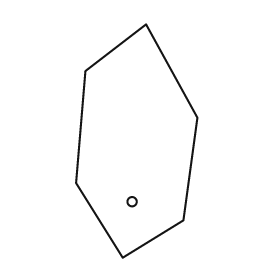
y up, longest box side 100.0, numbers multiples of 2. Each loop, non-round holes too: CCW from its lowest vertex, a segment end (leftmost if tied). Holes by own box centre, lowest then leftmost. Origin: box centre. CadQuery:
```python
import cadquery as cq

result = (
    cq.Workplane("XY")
    .moveTo(-6.0, -50.0)
    .lineTo(20.0, -34.0)
    .lineTo(26.0, 10.0)
    .lineTo(4.0, 50.0)
    .lineTo(-22.0, 30.0)
    .lineTo(-26.0, -18.0)
    .close()
    .moveTo(-2.0, -26.0)
    .circle(2.0)
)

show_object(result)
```